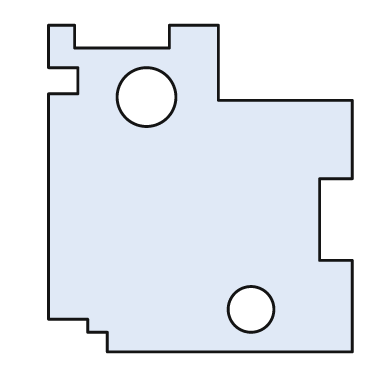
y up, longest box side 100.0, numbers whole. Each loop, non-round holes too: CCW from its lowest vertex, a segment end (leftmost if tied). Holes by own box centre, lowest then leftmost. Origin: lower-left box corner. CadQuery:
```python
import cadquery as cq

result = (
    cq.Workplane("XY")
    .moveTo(18.0, 0.0)
    .lineTo(93.0, 0.0)
    .lineTo(93.0, 28.0)
    .lineTo(83.0, 28.0)
    .lineTo(83.0, 53.0)
    .lineTo(93.0, 53.0)
    .lineTo(93.0, 77.0)
    .lineTo(52.0, 77.0)
    .lineTo(52.0, 100.0)
    .lineTo(37.0, 100.0)
    .lineTo(37.0, 93.0)
    .lineTo(8.0, 93.0)
    .lineTo(8.0, 100.0)
    .lineTo(0.0, 100.0)
    .lineTo(0.0, 87.0)
    .lineTo(9.0, 87.0)
    .lineTo(9.0, 79.0)
    .lineTo(0.0, 79.0)
    .lineTo(0.0, 10.0)
    .lineTo(12.0, 10.0)
    .lineTo(12.0, 6.0)
    .lineTo(18.0, 6.0)
    .close()
    .moveTo(62.0, 13.0)
    .circle(7.0)
    .moveTo(30.0, 78.0)
    .circle(9.0)
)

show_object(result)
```